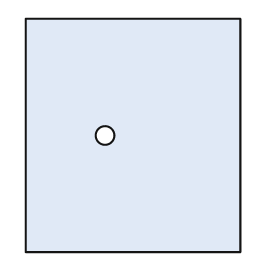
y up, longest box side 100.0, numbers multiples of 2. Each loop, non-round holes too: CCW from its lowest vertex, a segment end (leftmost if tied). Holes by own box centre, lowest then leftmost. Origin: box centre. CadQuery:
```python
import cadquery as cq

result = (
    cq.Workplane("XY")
    .moveTo(-46.0, -50.0)
    .lineTo(46.0, -50.0)
    .lineTo(46.0, 50.0)
    .lineTo(-46.0, 50.0)
    .close()
    .moveTo(-12.0, 0.0)
    .circle(4.0)
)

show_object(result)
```